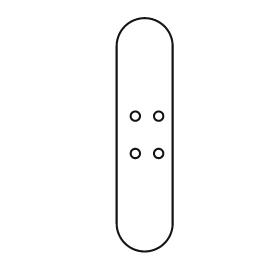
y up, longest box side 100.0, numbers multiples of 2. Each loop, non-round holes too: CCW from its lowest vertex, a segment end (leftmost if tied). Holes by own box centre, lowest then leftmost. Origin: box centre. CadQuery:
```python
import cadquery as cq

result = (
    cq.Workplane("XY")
    .moveTo(-12.0, -38.0)
    .threePointArc((0.0, -50.0), (12.0, -38.0))
    .lineTo(12.0, 38.0)
    .threePointArc((0.0, 50.0), (-12.0, 38.0))
    .close()
    .moveTo(-4.0, -8.0)
    .circle(2.0)
    .moveTo(6.0, -8.0)
    .circle(2.0)
    .moveTo(-4.0, 8.0)
    .circle(2.0)
    .moveTo(6.0, 8.0)
    .circle(2.0)
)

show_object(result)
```